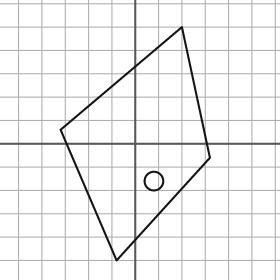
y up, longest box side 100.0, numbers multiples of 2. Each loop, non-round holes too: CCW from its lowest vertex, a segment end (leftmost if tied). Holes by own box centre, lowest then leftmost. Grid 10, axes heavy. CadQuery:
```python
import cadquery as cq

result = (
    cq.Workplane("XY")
    .moveTo(-8.0, -50.0)
    .lineTo(32.0, -6.0)
    .lineTo(20.0, 50.0)
    .lineTo(-32.0, 6.0)
    .close()
    .moveTo(8.0, -16.0)
    .circle(4.0)
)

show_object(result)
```